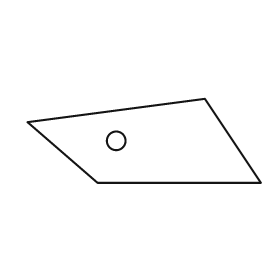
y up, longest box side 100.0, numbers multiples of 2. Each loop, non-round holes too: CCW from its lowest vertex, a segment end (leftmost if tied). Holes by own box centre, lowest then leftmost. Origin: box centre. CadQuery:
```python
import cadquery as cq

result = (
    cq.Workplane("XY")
    .moveTo(-20.0, -18.0)
    .lineTo(50.0, -18.0)
    .lineTo(26.0, 18.0)
    .lineTo(-50.0, 8.0)
    .close()
    .moveTo(-12.0, 0.0)
    .circle(4.0)
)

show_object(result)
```